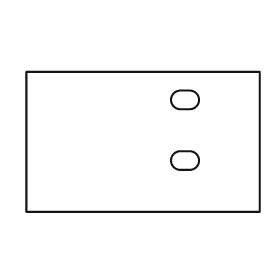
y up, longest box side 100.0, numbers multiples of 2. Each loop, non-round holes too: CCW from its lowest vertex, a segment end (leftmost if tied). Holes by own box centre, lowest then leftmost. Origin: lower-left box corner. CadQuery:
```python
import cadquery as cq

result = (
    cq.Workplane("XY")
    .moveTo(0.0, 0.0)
    .lineTo(100.0, 0.0)
    .lineTo(100.0, 60.0)
    .lineTo(0.0, 60.0)
    .close()
    .moveTo(66.0, 18.0)
    .lineTo(70.0, 18.0)
    .threePointArc((74.0, 22.0), (70.0, 26.0))
    .lineTo(66.0, 26.0)
    .threePointArc((62.0, 22.0), (66.0, 18.0))
    .close()
    .moveTo(66.0, 44.0)
    .lineTo(70.0, 44.0)
    .threePointArc((74.0, 48.0), (70.0, 52.0))
    .lineTo(66.0, 52.0)
    .threePointArc((62.0, 48.0), (66.0, 44.0))
    .close()
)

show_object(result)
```